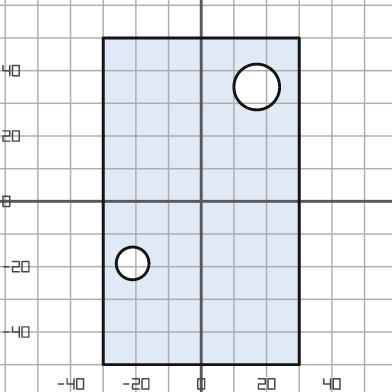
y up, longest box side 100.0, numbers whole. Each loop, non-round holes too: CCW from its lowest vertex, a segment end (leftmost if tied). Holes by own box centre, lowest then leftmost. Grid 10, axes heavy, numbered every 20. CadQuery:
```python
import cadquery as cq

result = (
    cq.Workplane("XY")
    .moveTo(-30.0, -50.0)
    .lineTo(30.0, -50.0)
    .lineTo(30.0, 50.0)
    .lineTo(-30.0, 50.0)
    .close()
    .moveTo(-21.0, -19.0)
    .circle(5.0)
    .moveTo(17.0, 35.0)
    .circle(7.0)
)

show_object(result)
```